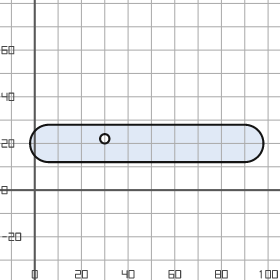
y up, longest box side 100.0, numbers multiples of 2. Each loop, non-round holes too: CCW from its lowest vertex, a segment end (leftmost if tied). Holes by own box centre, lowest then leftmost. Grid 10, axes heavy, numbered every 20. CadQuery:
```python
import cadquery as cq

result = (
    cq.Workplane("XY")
    .moveTo(6.0, 12.0)
    .lineTo(90.0, 12.0)
    .threePointArc((98.0, 20.0), (90.0, 28.0))
    .lineTo(6.0, 28.0)
    .threePointArc((-2.0, 20.0), (6.0, 12.0))
    .close()
    .moveTo(30.0, 22.0)
    .circle(2.0)
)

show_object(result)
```